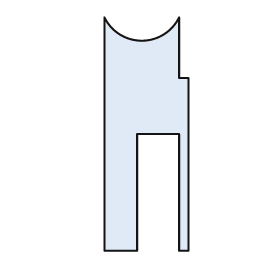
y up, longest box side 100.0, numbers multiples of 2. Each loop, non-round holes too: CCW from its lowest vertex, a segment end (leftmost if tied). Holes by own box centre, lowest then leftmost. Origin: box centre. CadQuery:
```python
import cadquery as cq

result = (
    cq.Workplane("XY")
    .moveTo(-18.0, -50.0)
    .lineTo(-4.0, -50.0)
    .lineTo(-4.0, 0.0)
    .lineTo(14.0, 0.0)
    .lineTo(14.0, -50.0)
    .lineTo(18.0, -50.0)
    .lineTo(18.0, 24.0)
    .lineTo(14.0, 24.0)
    .lineTo(14.0, 50.0)
    .threePointArc((-2.0, 40.0), (-18.0, 50.0))
    .close()
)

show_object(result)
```